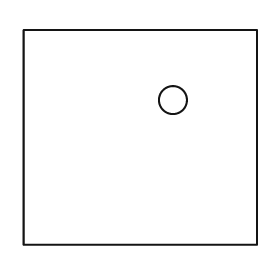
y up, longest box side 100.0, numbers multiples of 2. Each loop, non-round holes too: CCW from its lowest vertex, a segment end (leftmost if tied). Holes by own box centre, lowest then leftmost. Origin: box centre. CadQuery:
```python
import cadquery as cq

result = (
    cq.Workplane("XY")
    .moveTo(-50.0, -46.0)
    .lineTo(50.0, -46.0)
    .lineTo(50.0, 46.0)
    .lineTo(-50.0, 46.0)
    .close()
    .moveTo(14.0, 16.0)
    .circle(6.0)
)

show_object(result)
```